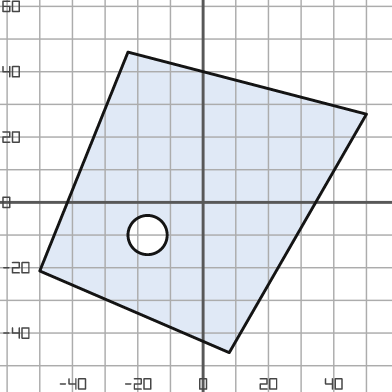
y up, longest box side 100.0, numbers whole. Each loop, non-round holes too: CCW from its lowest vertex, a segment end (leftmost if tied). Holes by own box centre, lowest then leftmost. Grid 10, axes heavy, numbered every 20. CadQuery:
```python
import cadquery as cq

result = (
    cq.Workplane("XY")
    .moveTo(8.0, -46.0)
    .lineTo(50.0, 27.0)
    .lineTo(-23.0, 46.0)
    .lineTo(-50.0, -21.0)
    .close()
    .moveTo(-17.0, -10.0)
    .circle(6.0)
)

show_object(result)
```